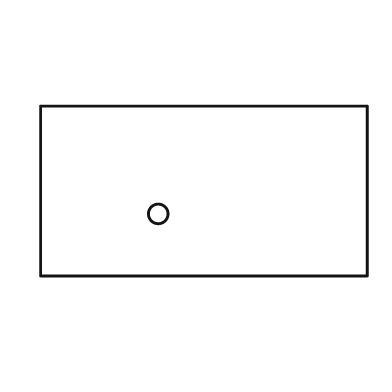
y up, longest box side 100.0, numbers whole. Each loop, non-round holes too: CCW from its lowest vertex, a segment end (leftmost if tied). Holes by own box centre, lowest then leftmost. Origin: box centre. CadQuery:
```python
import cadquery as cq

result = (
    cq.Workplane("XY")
    .moveTo(-50.0, -26.0)
    .lineTo(50.0, -26.0)
    .lineTo(50.0, 26.0)
    .lineTo(-50.0, 26.0)
    .close()
    .moveTo(-14.0, -7.0)
    .circle(3.0)
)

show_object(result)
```